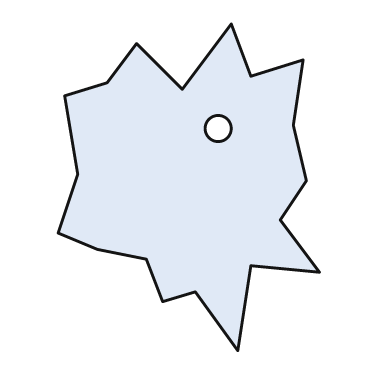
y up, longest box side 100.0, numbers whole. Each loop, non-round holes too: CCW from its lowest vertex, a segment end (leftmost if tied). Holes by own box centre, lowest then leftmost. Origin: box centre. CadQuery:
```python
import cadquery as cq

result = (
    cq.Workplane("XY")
    .moveTo(15.0, -50.0)
    .lineTo(19.0, -24.0)
    .lineTo(40.0, -26.0)
    .lineTo(28.0, -10.0)
    .lineTo(36.0, 2.0)
    .lineTo(32.0, 19.0)
    .lineTo(35.0, 39.0)
    .lineTo(19.0, 34.0)
    .lineTo(13.0, 50.0)
    .lineTo(-2.0, 30.0)
    .lineTo(-16.0, 44.0)
    .lineTo(-25.0, 32.0)
    .lineTo(-38.0, 28.0)
    .lineTo(-34.0, 4.0)
    .lineTo(-40.0, -14.0)
    .lineTo(-28.0, -19.0)
    .lineTo(-13.0, -22.0)
    .lineTo(-8.0, -35.0)
    .lineTo(2.0, -32.0)
    .close()
    .moveTo(9.0, 18.0)
    .circle(4.0)
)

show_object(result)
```